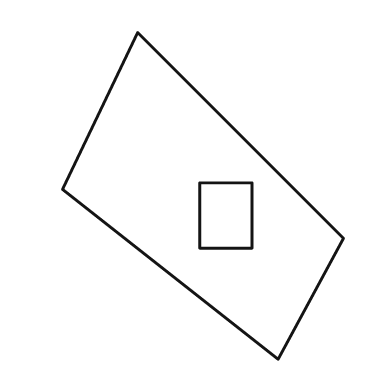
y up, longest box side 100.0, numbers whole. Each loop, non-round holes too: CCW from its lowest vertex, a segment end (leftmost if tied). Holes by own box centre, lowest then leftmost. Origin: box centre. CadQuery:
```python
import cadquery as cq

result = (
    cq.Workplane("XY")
    .moveTo(23.0, -50.0)
    .lineTo(43.0, -13.0)
    .lineTo(-20.0, 50.0)
    .lineTo(-43.0, 2.0)
    .close()
    .moveTo(-1.0, -16.0)
    .lineTo(15.0, -16.0)
    .lineTo(15.0, 4.0)
    .lineTo(-1.0, 4.0)
    .close()
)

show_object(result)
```